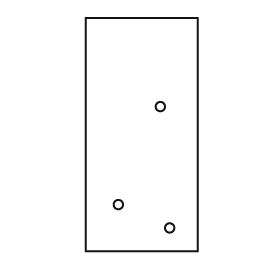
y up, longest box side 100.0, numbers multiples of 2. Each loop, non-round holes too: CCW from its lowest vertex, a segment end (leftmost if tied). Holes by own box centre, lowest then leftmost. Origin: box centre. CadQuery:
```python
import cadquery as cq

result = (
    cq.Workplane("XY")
    .moveTo(-24.0, -50.0)
    .lineTo(24.0, -50.0)
    .lineTo(24.0, 50.0)
    .lineTo(-24.0, 50.0)
    .close()
    .moveTo(12.0, -40.0)
    .circle(2.0)
    .moveTo(-10.0, -30.0)
    .circle(2.0)
    .moveTo(8.0, 12.0)
    .circle(2.0)
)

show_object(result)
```